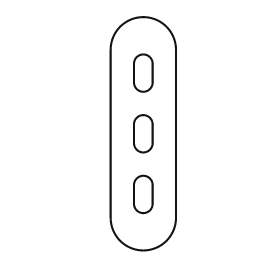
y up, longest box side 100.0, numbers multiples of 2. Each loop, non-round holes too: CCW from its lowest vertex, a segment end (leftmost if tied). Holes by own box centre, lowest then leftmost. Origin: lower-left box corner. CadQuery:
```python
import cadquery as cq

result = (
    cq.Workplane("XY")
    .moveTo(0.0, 14.0)
    .threePointArc((14.0, 0.0), (28.0, 14.0))
    .lineTo(28.0, 86.0)
    .threePointArc((14.0, 100.0), (0.0, 86.0))
    .close()
    .moveTo(10.0, 20.0)
    .threePointArc((14.0, 16.0), (18.0, 20.0))
    .lineTo(18.0, 28.0)
    .threePointArc((14.0, 32.0), (10.0, 28.0))
    .close()
    .moveTo(10.0, 46.0)
    .threePointArc((14.0, 42.0), (18.0, 46.0))
    .lineTo(18.0, 54.0)
    .threePointArc((14.0, 58.0), (10.0, 54.0))
    .close()
    .moveTo(10.0, 72.0)
    .threePointArc((14.0, 68.0), (18.0, 72.0))
    .lineTo(18.0, 80.0)
    .threePointArc((14.0, 84.0), (10.0, 80.0))
    .close()
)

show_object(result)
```